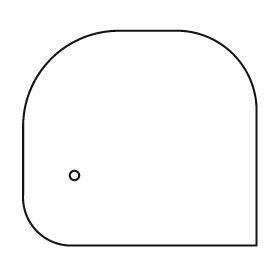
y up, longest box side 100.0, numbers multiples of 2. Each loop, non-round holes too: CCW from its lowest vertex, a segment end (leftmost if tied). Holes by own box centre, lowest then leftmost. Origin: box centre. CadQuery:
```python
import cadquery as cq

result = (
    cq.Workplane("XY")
    .moveTo(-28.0, -46.0)
    .lineTo(50.0, -46.0)
    .lineTo(50.0, 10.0)
    .threePointArc((40.0, 36.0), (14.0, 46.0))
    .lineTo(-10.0, 46.0)
    .threePointArc((-38.0, 34.0), (-50.0, 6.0))
    .lineTo(-50.0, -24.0)
    .threePointArc((-44.0, -40.0), (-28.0, -46.0))
    .close()
    .moveTo(-28.0, -16.0)
    .circle(2.0)
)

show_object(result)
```